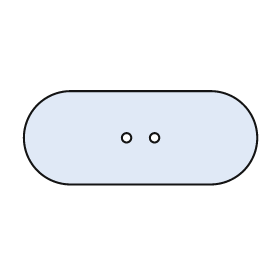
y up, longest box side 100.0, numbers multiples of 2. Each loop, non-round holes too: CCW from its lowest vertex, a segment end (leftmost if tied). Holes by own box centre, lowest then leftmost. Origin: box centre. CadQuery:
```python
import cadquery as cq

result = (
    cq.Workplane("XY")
    .moveTo(-30.0, -20.0)
    .lineTo(30.0, -20.0)
    .threePointArc((50.0, 0.0), (30.0, 20.0))
    .lineTo(-30.0, 20.0)
    .threePointArc((-50.0, 0.0), (-30.0, -20.0))
    .close()
    .moveTo(-6.0, 0.0)
    .circle(2.0)
    .moveTo(6.0, 0.0)
    .circle(2.0)
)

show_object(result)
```